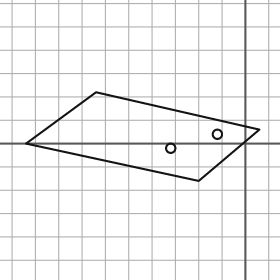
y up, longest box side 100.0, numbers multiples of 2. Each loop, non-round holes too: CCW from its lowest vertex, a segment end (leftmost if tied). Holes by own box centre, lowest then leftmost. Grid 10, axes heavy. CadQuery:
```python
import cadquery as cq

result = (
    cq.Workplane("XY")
    .moveTo(-20.0, -16.0)
    .lineTo(6.0, 6.0)
    .lineTo(-64.0, 22.0)
    .lineTo(-94.0, 0.0)
    .close()
    .moveTo(-32.0, -2.0)
    .circle(2.0)
    .moveTo(-12.0, 4.0)
    .circle(2.0)
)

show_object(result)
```